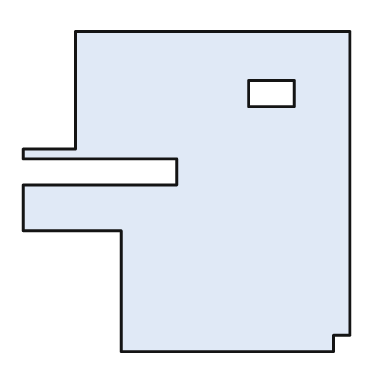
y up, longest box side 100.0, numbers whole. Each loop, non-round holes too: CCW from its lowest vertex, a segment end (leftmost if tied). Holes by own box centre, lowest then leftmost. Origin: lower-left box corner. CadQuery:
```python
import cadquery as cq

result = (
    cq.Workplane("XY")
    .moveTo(30.0, 0.0)
    .lineTo(95.0, 0.0)
    .lineTo(95.0, 5.0)
    .lineTo(100.0, 5.0)
    .lineTo(100.0, 98.0)
    .lineTo(16.0, 98.0)
    .lineTo(16.0, 62.0)
    .lineTo(0.0, 62.0)
    .lineTo(0.0, 59.0)
    .lineTo(47.0, 59.0)
    .lineTo(47.0, 51.0)
    .lineTo(0.0, 51.0)
    .lineTo(0.0, 37.0)
    .lineTo(30.0, 37.0)
    .close()
    .moveTo(69.0, 75.0)
    .lineTo(83.0, 75.0)
    .lineTo(83.0, 83.0)
    .lineTo(69.0, 83.0)
    .close()
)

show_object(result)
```